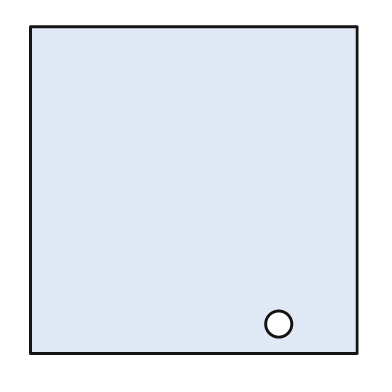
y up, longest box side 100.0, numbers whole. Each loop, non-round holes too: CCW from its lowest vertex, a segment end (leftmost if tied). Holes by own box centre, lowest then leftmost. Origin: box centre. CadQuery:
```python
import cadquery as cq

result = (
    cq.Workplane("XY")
    .moveTo(-50.0, -50.0)
    .lineTo(50.0, -50.0)
    .lineTo(50.0, 50.0)
    .lineTo(-50.0, 50.0)
    .close()
    .moveTo(26.0, -41.0)
    .circle(4.0)
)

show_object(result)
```